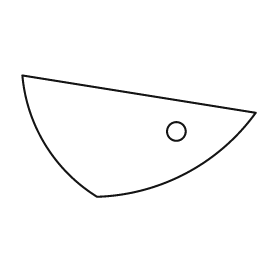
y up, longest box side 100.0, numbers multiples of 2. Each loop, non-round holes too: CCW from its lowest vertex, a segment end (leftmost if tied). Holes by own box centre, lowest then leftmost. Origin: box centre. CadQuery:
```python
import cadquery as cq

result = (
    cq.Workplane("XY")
    .moveTo(-18.0, -26.0)
    .threePointArc((20.0, -16.0), (50.0, 10.0))
    .lineTo(-50.0, 26.0)
    .threePointArc((-40.0, -4.0), (-18.0, -26.0))
    .close()
    .moveTo(16.0, 2.0)
    .circle(4.0)
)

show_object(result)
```